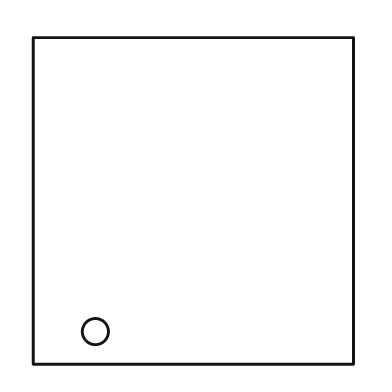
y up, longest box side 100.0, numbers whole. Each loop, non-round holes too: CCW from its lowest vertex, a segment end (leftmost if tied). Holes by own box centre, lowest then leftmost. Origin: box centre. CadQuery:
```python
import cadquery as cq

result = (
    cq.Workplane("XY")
    .moveTo(-49.0, -50.0)
    .lineTo(49.0, -50.0)
    .lineTo(49.0, 50.0)
    .lineTo(-49.0, 50.0)
    .close()
    .moveTo(-30.0, -40.0)
    .circle(4.0)
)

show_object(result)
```